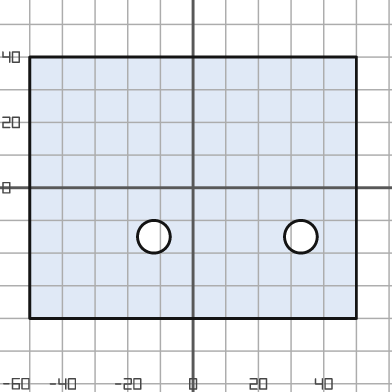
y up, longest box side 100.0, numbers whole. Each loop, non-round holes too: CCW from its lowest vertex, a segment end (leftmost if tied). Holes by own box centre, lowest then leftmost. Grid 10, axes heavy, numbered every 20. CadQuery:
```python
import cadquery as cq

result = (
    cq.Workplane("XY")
    .moveTo(-50.0, -40.0)
    .lineTo(50.0, -40.0)
    .lineTo(50.0, 40.0)
    .lineTo(-50.0, 40.0)
    .close()
    .moveTo(-12.0, -15.0)
    .circle(5.0)
    .moveTo(33.0, -15.0)
    .circle(5.0)
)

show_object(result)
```